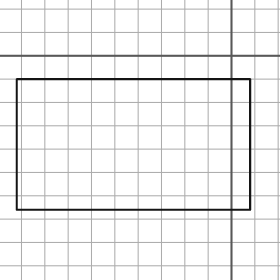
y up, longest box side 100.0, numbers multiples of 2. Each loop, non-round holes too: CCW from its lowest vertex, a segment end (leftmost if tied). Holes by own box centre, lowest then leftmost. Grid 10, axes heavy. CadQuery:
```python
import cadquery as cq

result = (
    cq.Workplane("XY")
    .moveTo(-92.0, -66.0)
    .lineTo(8.0, -66.0)
    .lineTo(8.0, -10.0)
    .lineTo(-92.0, -10.0)
    .close()
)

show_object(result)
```